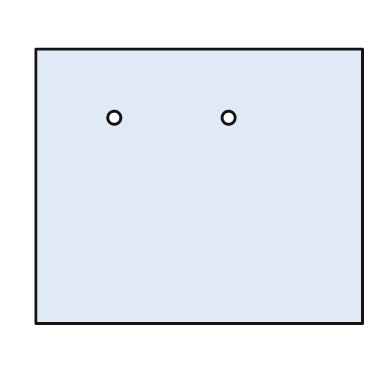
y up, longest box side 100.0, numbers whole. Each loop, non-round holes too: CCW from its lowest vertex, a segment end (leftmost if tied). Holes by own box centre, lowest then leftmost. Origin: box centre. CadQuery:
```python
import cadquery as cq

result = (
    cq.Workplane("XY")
    .moveTo(-50.0, -42.0)
    .lineTo(50.0, -42.0)
    .lineTo(50.0, 42.0)
    .lineTo(-50.0, 42.0)
    .close()
    .moveTo(-26.0, 21.0)
    .circle(2.0)
    .moveTo(9.0, 21.0)
    .circle(2.0)
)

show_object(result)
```